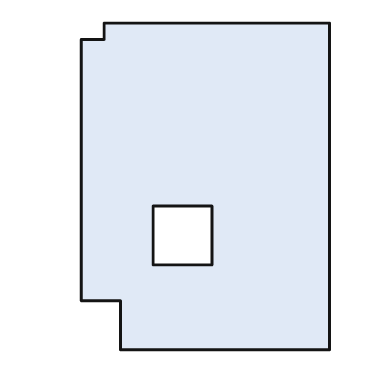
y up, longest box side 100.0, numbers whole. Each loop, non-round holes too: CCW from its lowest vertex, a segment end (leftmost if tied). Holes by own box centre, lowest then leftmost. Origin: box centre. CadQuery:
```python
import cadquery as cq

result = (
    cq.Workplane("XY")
    .moveTo(-26.0, -50.0)
    .lineTo(38.0, -50.0)
    .lineTo(38.0, 50.0)
    .lineTo(-31.0, 50.0)
    .lineTo(-31.0, 45.0)
    .lineTo(-38.0, 45.0)
    .lineTo(-38.0, -35.0)
    .lineTo(-26.0, -35.0)
    .close()
    .moveTo(-16.0, -24.0)
    .lineTo(2.0, -24.0)
    .lineTo(2.0, -6.0)
    .lineTo(-16.0, -6.0)
    .close()
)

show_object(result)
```